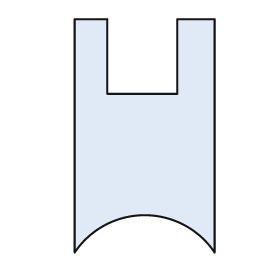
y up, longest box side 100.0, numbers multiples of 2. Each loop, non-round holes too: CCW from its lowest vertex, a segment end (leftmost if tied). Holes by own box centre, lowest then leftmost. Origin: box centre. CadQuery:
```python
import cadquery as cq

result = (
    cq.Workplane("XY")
    .moveTo(-30.0, -50.0)
    .threePointArc((0.0, -34.0), (30.0, -50.0))
    .lineTo(30.0, 50.0)
    .lineTo(14.0, 50.0)
    .lineTo(14.0, 18.0)
    .lineTo(-16.0, 18.0)
    .lineTo(-16.0, 50.0)
    .lineTo(-30.0, 50.0)
    .close()
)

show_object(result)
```